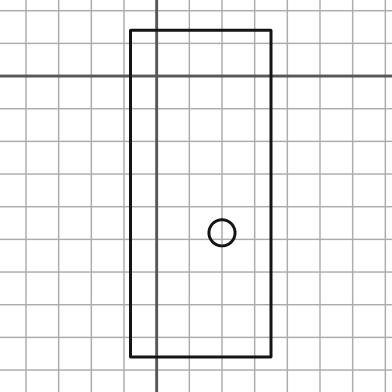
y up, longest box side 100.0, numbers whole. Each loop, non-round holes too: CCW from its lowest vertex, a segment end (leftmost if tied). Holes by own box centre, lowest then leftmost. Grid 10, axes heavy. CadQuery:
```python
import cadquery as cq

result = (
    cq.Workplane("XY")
    .moveTo(-8.0, -86.0)
    .lineTo(35.0, -86.0)
    .lineTo(35.0, 14.0)
    .lineTo(-8.0, 14.0)
    .close()
    .moveTo(20.0, -48.0)
    .circle(4.0)
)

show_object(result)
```